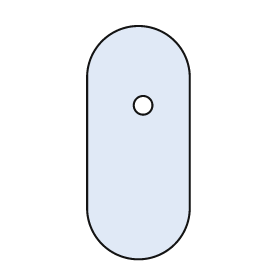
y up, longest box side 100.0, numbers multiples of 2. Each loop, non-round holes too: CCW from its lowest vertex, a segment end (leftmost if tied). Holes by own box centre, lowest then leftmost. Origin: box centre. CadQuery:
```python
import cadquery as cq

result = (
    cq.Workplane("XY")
    .moveTo(-22.0, -28.0)
    .threePointArc((0.0, -50.0), (22.0, -28.0))
    .lineTo(22.0, 28.0)
    .threePointArc((0.0, 50.0), (-22.0, 28.0))
    .close()
    .moveTo(2.0, 16.0)
    .circle(4.0)
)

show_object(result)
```